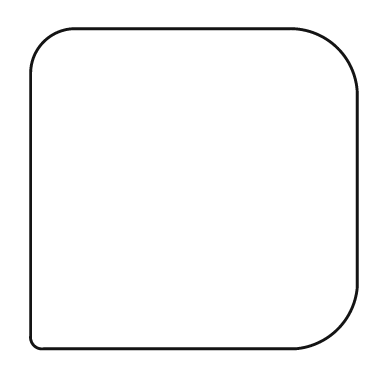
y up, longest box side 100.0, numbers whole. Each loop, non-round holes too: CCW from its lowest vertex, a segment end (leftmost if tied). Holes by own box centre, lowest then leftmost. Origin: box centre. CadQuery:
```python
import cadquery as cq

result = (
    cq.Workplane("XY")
    .moveTo(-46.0, -49.0)
    .lineTo(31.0, -49.0)
    .threePointArc((44.0, -43.0), (50.0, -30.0))
    .lineTo(50.0, 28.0)
    .threePointArc((44.0, 43.0), (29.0, 49.0))
    .lineTo(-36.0, 49.0)
    .threePointArc((-46.0, 45.0), (-50.0, 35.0))
    .lineTo(-50.0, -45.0)
    .threePointArc((-49.0, -48.0), (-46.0, -49.0))
    .close()
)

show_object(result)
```